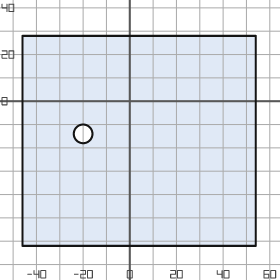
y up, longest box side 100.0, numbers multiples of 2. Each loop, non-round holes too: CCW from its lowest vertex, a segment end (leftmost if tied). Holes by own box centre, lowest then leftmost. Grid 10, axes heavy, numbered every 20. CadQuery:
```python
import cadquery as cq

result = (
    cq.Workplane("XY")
    .moveTo(-46.0, -62.0)
    .lineTo(54.0, -62.0)
    .lineTo(54.0, 28.0)
    .lineTo(-46.0, 28.0)
    .close()
    .moveTo(-20.0, -14.0)
    .circle(4.0)
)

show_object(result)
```